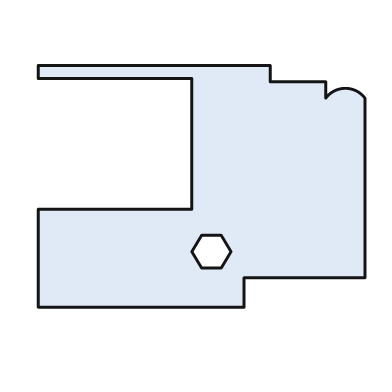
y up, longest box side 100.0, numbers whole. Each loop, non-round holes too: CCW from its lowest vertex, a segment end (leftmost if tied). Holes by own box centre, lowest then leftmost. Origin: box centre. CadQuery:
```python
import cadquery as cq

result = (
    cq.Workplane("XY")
    .moveTo(-50.0, -37.0)
    .lineTo(13.0, -37.0)
    .lineTo(13.0, -28.0)
    .lineTo(50.0, -28.0)
    .lineTo(50.0, 27.0)
    .threePointArc((44.0, 30.0), (38.0, 27.0))
    .lineTo(38.0, 32.0)
    .lineTo(21.0, 32.0)
    .lineTo(21.0, 37.0)
    .lineTo(-50.0, 37.0)
    .lineTo(-50.0, 33.0)
    .lineTo(-3.0, 33.0)
    .lineTo(-3.0, -7.0)
    .lineTo(-50.0, -7.0)
    .close()
    .moveTo(0.0, -25.0)
    .lineTo(6.0, -25.0)
    .lineTo(9.0, -20.0)
    .lineTo(6.0, -15.0)
    .lineTo(0.0, -15.0)
    .lineTo(-3.0, -20.0)
    .close()
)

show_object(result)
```